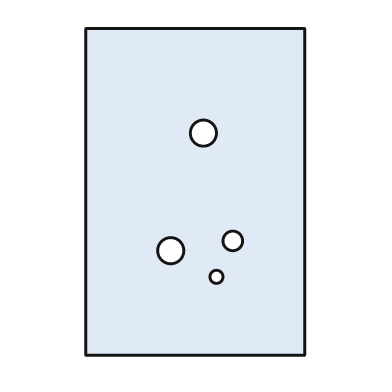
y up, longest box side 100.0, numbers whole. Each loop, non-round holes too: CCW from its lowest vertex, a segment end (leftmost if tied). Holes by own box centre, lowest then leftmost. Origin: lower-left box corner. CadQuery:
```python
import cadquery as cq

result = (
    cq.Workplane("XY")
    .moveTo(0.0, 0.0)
    .lineTo(67.0, 0.0)
    .lineTo(67.0, 100.0)
    .lineTo(0.0, 100.0)
    .close()
    .moveTo(40.0, 24.0)
    .circle(2.0)
    .moveTo(26.0, 32.0)
    .circle(4.0)
    .moveTo(45.0, 35.0)
    .circle(3.0)
    .moveTo(36.0, 68.0)
    .circle(4.0)
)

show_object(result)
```